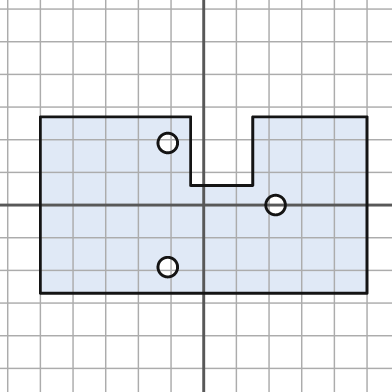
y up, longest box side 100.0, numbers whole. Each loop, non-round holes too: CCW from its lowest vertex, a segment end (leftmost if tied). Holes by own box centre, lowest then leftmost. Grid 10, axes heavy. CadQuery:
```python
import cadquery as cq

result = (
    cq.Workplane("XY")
    .moveTo(-50.0, -27.0)
    .lineTo(50.0, -27.0)
    .lineTo(50.0, 27.0)
    .lineTo(15.0, 27.0)
    .lineTo(15.0, 6.0)
    .lineTo(-4.0, 6.0)
    .lineTo(-4.0, 27.0)
    .lineTo(-50.0, 27.0)
    .close()
    .moveTo(-11.0, -19.0)
    .circle(3.0)
    .moveTo(22.0, 0.0)
    .circle(3.0)
    .moveTo(-11.0, 19.0)
    .circle(3.0)
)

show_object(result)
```